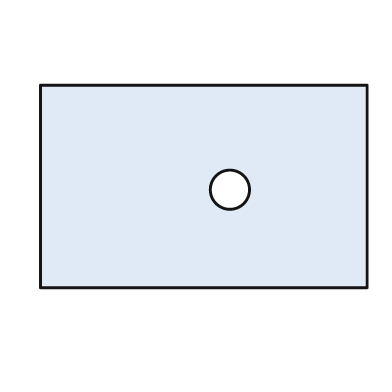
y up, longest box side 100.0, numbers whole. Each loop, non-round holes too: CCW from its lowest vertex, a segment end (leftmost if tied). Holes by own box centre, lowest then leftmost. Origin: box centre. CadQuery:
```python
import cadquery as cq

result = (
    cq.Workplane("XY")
    .moveTo(-50.0, -31.0)
    .lineTo(50.0, -31.0)
    .lineTo(50.0, 31.0)
    .lineTo(-50.0, 31.0)
    .close()
    .moveTo(8.0, -1.0)
    .circle(6.0)
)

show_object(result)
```